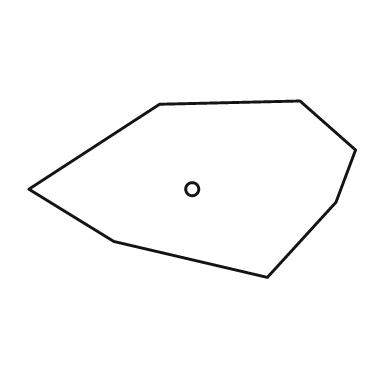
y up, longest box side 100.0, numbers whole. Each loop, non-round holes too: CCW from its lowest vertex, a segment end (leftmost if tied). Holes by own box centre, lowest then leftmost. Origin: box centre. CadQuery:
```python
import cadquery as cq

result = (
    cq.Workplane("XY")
    .moveTo(23.0, -27.0)
    .lineTo(44.0, -4.0)
    .lineTo(50.0, 12.0)
    .lineTo(33.0, 27.0)
    .lineTo(-10.0, 26.0)
    .lineTo(-50.0, 0.0)
    .lineTo(-24.0, -16.0)
    .close()
    .moveTo(0.0, 0.0)
    .circle(2.0)
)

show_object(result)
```